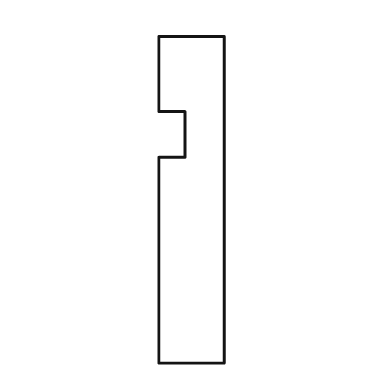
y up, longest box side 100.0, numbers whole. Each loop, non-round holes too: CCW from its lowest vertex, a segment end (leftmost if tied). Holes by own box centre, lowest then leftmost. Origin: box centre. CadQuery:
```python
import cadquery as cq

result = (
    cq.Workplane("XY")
    .moveTo(-10.0, -50.0)
    .lineTo(10.0, -50.0)
    .lineTo(10.0, 50.0)
    .lineTo(-10.0, 50.0)
    .lineTo(-10.0, 27.0)
    .lineTo(-2.0, 27.0)
    .lineTo(-2.0, 13.0)
    .lineTo(-10.0, 13.0)
    .close()
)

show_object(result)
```